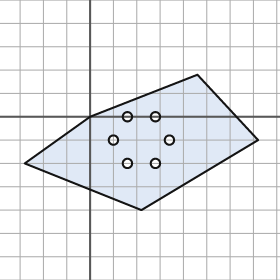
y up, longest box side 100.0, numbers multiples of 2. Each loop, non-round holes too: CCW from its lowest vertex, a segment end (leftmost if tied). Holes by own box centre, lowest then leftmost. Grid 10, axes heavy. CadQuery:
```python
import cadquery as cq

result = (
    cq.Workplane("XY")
    .moveTo(22.0, -40.0)
    .lineTo(72.0, -10.0)
    .lineTo(46.0, 18.0)
    .lineTo(0.0, 0.0)
    .lineTo(-28.0, -20.0)
    .close()
    .moveTo(16.0, -20.0)
    .circle(2.0)
    .moveTo(28.0, -20.0)
    .circle(2.0)
    .moveTo(10.0, -10.0)
    .circle(2.0)
    .moveTo(34.0, -10.0)
    .circle(2.0)
    .moveTo(16.0, 0.0)
    .circle(2.0)
    .moveTo(28.0, 0.0)
    .circle(2.0)
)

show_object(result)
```